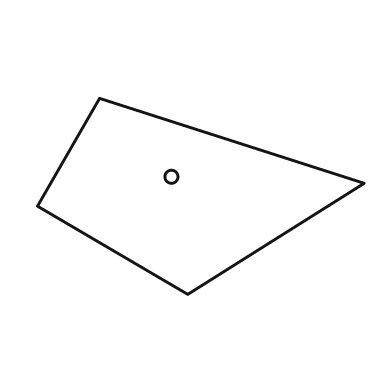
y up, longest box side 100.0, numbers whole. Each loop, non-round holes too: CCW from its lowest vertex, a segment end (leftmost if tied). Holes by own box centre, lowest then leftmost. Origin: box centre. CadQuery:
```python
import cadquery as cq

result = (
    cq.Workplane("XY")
    .moveTo(-4.0, -30.0)
    .lineTo(50.0, 4.0)
    .lineTo(-31.0, 30.0)
    .lineTo(-50.0, -3.0)
    .close()
    .moveTo(-9.0, 6.0)
    .circle(2.0)
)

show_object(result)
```